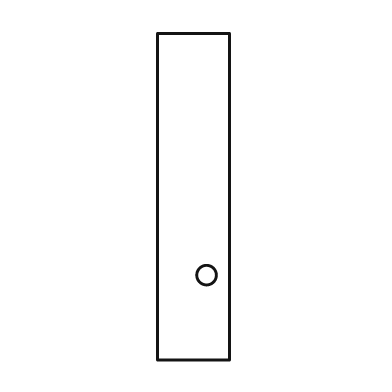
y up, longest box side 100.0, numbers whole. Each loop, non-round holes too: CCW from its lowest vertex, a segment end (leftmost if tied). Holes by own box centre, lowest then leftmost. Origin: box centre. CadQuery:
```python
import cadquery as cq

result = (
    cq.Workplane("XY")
    .moveTo(-11.0, -50.0)
    .lineTo(11.0, -50.0)
    .lineTo(11.0, 50.0)
    .lineTo(-11.0, 50.0)
    .close()
    .moveTo(4.0, -24.0)
    .circle(3.0)
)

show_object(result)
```